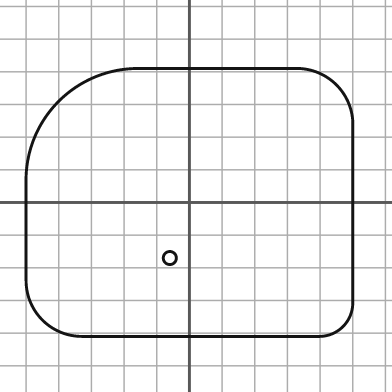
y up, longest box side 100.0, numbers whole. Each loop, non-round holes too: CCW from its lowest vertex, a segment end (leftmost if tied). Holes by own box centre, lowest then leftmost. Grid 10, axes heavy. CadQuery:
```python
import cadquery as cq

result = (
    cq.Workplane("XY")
    .moveTo(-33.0, -41.0)
    .lineTo(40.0, -41.0)
    .threePointArc((47.0, -38.0), (50.0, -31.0))
    .lineTo(50.0, 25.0)
    .threePointArc((45.0, 36.0), (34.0, 41.0))
    .lineTo(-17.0, 41.0)
    .threePointArc((-40.0, 31.0), (-50.0, 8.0))
    .lineTo(-50.0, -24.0)
    .threePointArc((-45.0, -36.0), (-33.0, -41.0))
    .close()
    .moveTo(-6.0, -17.0)
    .circle(2.0)
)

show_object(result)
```